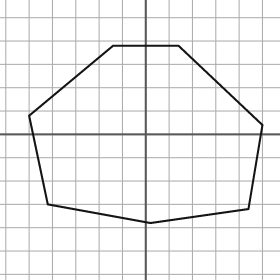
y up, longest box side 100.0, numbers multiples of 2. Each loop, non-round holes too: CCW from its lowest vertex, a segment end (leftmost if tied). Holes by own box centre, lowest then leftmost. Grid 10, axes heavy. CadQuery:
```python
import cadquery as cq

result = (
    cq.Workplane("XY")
    .moveTo(2.0, -38.0)
    .lineTo(44.0, -32.0)
    .lineTo(50.0, 4.0)
    .lineTo(14.0, 38.0)
    .lineTo(-14.0, 38.0)
    .lineTo(-50.0, 8.0)
    .lineTo(-42.0, -30.0)
    .close()
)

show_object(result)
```